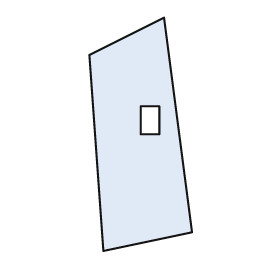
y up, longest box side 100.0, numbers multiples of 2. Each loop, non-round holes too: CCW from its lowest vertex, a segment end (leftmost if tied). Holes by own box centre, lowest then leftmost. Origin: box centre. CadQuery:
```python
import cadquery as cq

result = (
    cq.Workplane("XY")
    .moveTo(-16.0, -50.0)
    .lineTo(22.0, -42.0)
    .lineTo(10.0, 50.0)
    .lineTo(-22.0, 34.0)
    .close()
    .moveTo(0.0, 0.0)
    .lineTo(8.0, 0.0)
    .lineTo(8.0, 12.0)
    .lineTo(0.0, 12.0)
    .close()
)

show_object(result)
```